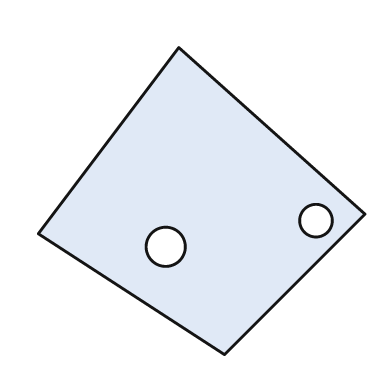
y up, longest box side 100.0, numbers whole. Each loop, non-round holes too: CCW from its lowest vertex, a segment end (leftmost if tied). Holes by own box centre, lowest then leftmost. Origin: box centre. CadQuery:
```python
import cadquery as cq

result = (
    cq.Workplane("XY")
    .moveTo(7.0, -47.0)
    .lineTo(50.0, -4.0)
    .lineTo(-7.0, 47.0)
    .lineTo(-50.0, -10.0)
    .close()
    .moveTo(-11.0, -14.0)
    .circle(6.0)
    .moveTo(35.0, -6.0)
    .circle(5.0)
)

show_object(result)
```